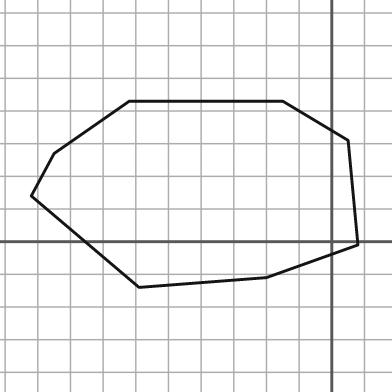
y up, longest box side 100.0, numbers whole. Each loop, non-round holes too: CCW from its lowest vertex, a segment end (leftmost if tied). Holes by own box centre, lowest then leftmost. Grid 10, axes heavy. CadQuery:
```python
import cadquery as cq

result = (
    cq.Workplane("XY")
    .moveTo(-59.0, -14.0)
    .lineTo(-20.0, -11.0)
    .lineTo(8.0, -1.0)
    .lineTo(5.0, 31.0)
    .lineTo(-15.0, 43.0)
    .lineTo(-62.0, 43.0)
    .lineTo(-85.0, 27.0)
    .lineTo(-92.0, 14.0)
    .close()
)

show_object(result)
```